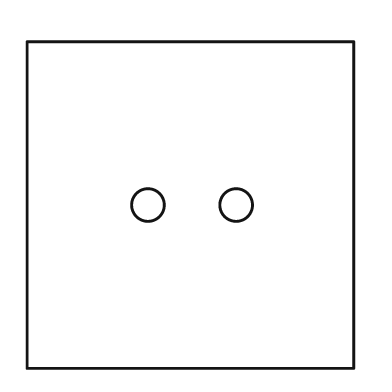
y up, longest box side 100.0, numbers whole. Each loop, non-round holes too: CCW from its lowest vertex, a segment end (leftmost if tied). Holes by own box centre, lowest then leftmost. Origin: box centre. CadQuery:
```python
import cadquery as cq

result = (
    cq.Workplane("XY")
    .moveTo(-50.0, -50.0)
    .lineTo(50.0, -50.0)
    .lineTo(50.0, 50.0)
    .lineTo(-50.0, 50.0)
    .close()
    .moveTo(-13.0, 0.0)
    .circle(5.0)
    .moveTo(14.0, 0.0)
    .circle(5.0)
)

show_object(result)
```